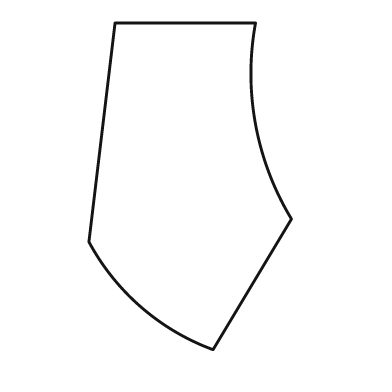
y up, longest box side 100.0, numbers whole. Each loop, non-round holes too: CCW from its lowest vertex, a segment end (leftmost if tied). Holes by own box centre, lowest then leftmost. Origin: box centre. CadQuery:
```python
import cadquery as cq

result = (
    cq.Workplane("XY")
    .moveTo(7.0, -50.0)
    .lineTo(31.0, -10.0)
    .threePointArc((20.0, 19.0), (20.0, 50.0))
    .lineTo(-23.0, 50.0)
    .lineTo(-31.0, -17.0)
    .threePointArc((-15.0, -37.0), (7.0, -50.0))
    .close()
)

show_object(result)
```